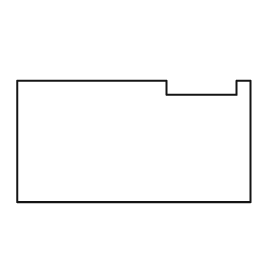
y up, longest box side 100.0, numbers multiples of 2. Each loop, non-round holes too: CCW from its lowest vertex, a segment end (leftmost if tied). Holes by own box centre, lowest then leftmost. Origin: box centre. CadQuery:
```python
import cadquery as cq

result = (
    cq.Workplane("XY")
    .moveTo(-50.0, -26.0)
    .lineTo(50.0, -26.0)
    .lineTo(50.0, 26.0)
    .lineTo(44.0, 26.0)
    .lineTo(44.0, 20.0)
    .lineTo(14.0, 20.0)
    .lineTo(14.0, 26.0)
    .lineTo(-50.0, 26.0)
    .close()
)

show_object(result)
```